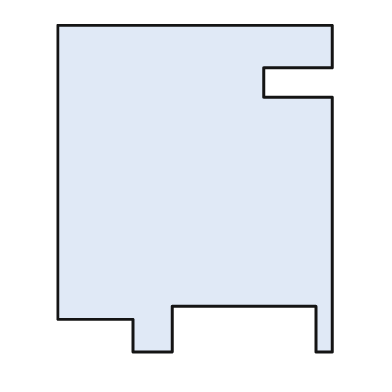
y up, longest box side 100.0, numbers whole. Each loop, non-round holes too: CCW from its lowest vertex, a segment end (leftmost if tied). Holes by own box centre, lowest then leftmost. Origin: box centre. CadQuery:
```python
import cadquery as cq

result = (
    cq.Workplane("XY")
    .moveTo(-19.0, -50.0)
    .lineTo(-7.0, -50.0)
    .lineTo(-7.0, -36.0)
    .lineTo(37.0, -36.0)
    .lineTo(37.0, -50.0)
    .lineTo(42.0, -50.0)
    .lineTo(42.0, 28.0)
    .lineTo(21.0, 28.0)
    .lineTo(21.0, 37.0)
    .lineTo(42.0, 37.0)
    .lineTo(42.0, 50.0)
    .lineTo(-42.0, 50.0)
    .lineTo(-42.0, -40.0)
    .lineTo(-19.0, -40.0)
    .close()
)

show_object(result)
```